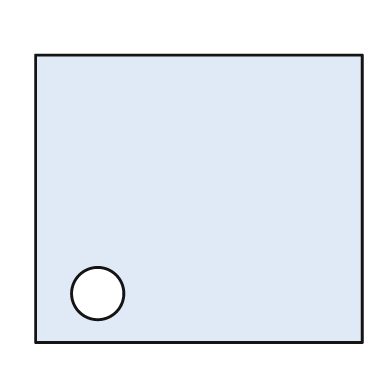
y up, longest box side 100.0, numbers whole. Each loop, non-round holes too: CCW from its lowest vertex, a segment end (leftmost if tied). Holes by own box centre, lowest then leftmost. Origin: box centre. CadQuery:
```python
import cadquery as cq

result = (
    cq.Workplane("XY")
    .moveTo(-50.0, -44.0)
    .lineTo(50.0, -44.0)
    .lineTo(50.0, 44.0)
    .lineTo(-50.0, 44.0)
    .close()
    .moveTo(-31.0, -29.0)
    .circle(8.0)
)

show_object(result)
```